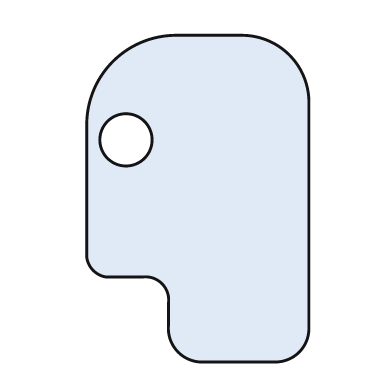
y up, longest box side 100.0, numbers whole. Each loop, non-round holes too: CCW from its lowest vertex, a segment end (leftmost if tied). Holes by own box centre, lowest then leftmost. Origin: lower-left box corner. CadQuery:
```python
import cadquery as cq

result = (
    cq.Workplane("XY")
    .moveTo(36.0, 0.0)
    .lineTo(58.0, 0.0)
    .threePointArc((65.0, 3.0), (68.0, 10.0))
    .lineTo(68.0, 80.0)
    .threePointArc((62.0, 94.0), (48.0, 100.0))
    .lineTo(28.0, 100.0)
    .threePointArc((8.0, 92.0), (0.0, 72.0))
    .lineTo(0.0, 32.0)
    .threePointArc((2.0, 28.0), (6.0, 26.0))
    .lineTo(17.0, 26.0)
    .threePointArc((23.0, 24.0), (25.0, 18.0))
    .lineTo(25.0, 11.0)
    .threePointArc((28.0, 3.0), (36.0, 0.0))
    .close()
    .moveTo(12.0, 68.0)
    .circle(8.0)
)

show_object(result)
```